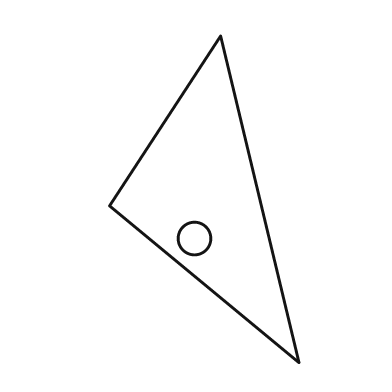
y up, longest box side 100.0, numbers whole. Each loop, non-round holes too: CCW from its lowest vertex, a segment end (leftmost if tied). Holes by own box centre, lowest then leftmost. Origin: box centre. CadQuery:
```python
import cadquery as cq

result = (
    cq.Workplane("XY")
    .moveTo(29.0, -50.0)
    .lineTo(5.0, 50.0)
    .lineTo(-29.0, -2.0)
    .close()
    .moveTo(-3.0, -12.0)
    .circle(5.0)
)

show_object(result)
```